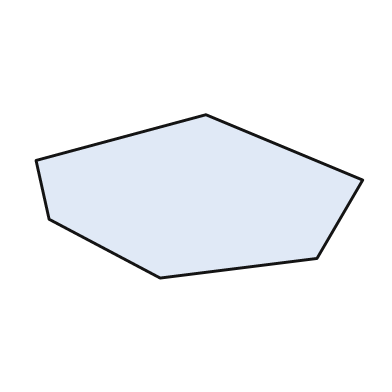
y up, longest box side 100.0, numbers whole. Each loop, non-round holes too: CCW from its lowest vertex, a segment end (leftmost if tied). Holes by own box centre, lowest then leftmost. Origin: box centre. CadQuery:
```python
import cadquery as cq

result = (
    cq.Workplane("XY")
    .moveTo(-12.0, -25.0)
    .lineTo(36.0, -19.0)
    .lineTo(50.0, 5.0)
    .lineTo(2.0, 25.0)
    .lineTo(-50.0, 11.0)
    .lineTo(-46.0, -7.0)
    .close()
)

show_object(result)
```